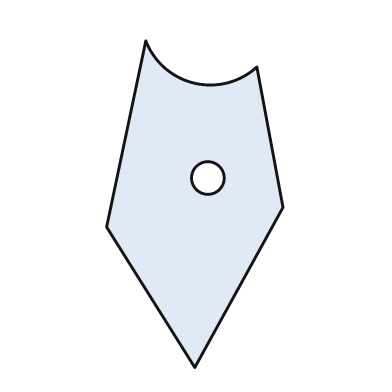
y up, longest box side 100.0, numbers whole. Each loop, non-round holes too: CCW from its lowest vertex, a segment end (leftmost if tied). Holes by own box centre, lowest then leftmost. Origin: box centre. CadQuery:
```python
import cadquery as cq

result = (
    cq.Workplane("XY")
    .moveTo(0.0, -50.0)
    .lineTo(27.0, -1.0)
    .lineTo(19.0, 42.0)
    .threePointArc((0.0, 37.0), (-15.0, 50.0))
    .lineTo(-27.0, -7.0)
    .close()
    .moveTo(4.0, 8.0)
    .circle(5.0)
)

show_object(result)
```